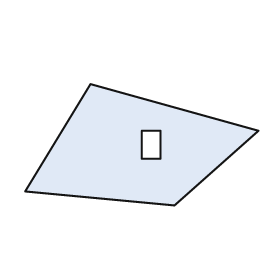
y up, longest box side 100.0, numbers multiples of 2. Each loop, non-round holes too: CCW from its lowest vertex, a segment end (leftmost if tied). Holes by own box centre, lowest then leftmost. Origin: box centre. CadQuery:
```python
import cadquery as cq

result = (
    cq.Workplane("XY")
    .moveTo(14.0, -26.0)
    .lineTo(50.0, 6.0)
    .lineTo(-22.0, 26.0)
    .lineTo(-50.0, -20.0)
    .close()
    .moveTo(0.0, -6.0)
    .lineTo(8.0, -6.0)
    .lineTo(8.0, 6.0)
    .lineTo(0.0, 6.0)
    .close()
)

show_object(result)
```